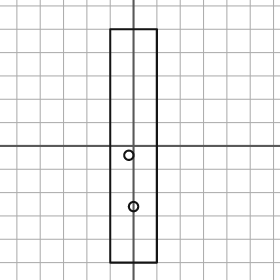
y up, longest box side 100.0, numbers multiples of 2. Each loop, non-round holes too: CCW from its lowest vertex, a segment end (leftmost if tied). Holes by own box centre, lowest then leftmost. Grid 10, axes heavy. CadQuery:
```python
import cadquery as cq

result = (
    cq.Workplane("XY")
    .moveTo(-10.0, -50.0)
    .lineTo(10.0, -50.0)
    .lineTo(10.0, 50.0)
    .lineTo(-10.0, 50.0)
    .close()
    .moveTo(0.0, -26.0)
    .circle(2.0)
    .moveTo(-2.0, -4.0)
    .circle(2.0)
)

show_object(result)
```